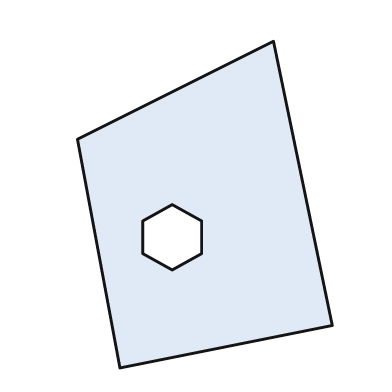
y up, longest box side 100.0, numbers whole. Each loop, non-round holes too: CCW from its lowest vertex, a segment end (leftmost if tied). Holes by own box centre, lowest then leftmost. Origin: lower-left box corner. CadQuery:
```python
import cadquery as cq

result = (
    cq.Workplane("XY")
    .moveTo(13.0, 0.0)
    .lineTo(78.0, 13.0)
    .lineTo(60.0, 100.0)
    .lineTo(0.0, 70.0)
    .close()
    .moveTo(29.0, 30.0)
    .lineTo(38.0, 35.0)
    .lineTo(38.0, 45.0)
    .lineTo(29.0, 50.0)
    .lineTo(20.0, 45.0)
    .lineTo(20.0, 35.0)
    .close()
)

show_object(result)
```